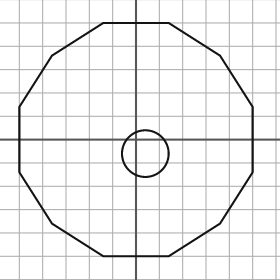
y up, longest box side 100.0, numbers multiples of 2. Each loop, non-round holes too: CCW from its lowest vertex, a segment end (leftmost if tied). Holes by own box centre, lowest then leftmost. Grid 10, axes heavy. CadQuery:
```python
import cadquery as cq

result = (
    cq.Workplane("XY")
    .moveTo(-14.0, -50.0)
    .lineTo(14.0, -50.0)
    .lineTo(36.0, -36.0)
    .lineTo(50.0, -14.0)
    .lineTo(50.0, 14.0)
    .lineTo(36.0, 36.0)
    .lineTo(14.0, 50.0)
    .lineTo(-14.0, 50.0)
    .lineTo(-36.0, 36.0)
    .lineTo(-50.0, 14.0)
    .lineTo(-50.0, -14.0)
    .lineTo(-36.0, -36.0)
    .close()
    .moveTo(4.0, -6.0)
    .circle(10.0)
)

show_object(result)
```